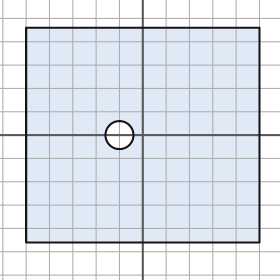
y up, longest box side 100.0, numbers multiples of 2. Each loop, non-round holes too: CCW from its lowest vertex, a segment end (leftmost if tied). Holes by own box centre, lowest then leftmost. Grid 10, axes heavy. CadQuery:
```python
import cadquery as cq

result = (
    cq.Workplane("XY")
    .moveTo(-50.0, -46.0)
    .lineTo(50.0, -46.0)
    .lineTo(50.0, 46.0)
    .lineTo(-50.0, 46.0)
    .close()
    .moveTo(-10.0, 0.0)
    .circle(6.0)
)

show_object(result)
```